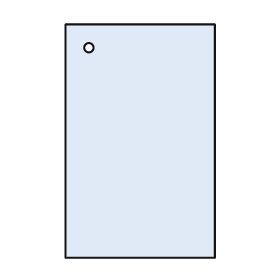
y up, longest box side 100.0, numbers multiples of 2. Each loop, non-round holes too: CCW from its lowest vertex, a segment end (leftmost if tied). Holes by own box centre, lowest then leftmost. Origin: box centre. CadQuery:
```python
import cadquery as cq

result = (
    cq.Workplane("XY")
    .moveTo(-32.0, -50.0)
    .lineTo(32.0, -50.0)
    .lineTo(32.0, 50.0)
    .lineTo(-32.0, 50.0)
    .close()
    .moveTo(-22.0, 40.0)
    .circle(2.0)
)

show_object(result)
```